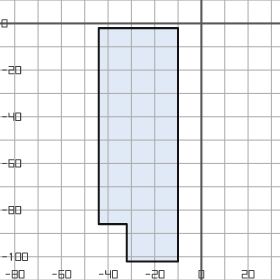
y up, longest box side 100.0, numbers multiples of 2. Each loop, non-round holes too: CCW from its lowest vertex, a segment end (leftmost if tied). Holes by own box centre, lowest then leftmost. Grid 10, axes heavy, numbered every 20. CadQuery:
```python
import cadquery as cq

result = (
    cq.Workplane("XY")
    .moveTo(-32.0, -102.0)
    .lineTo(-10.0, -102.0)
    .lineTo(-10.0, -2.0)
    .lineTo(-44.0, -2.0)
    .lineTo(-44.0, -86.0)
    .lineTo(-32.0, -86.0)
    .close()
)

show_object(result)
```